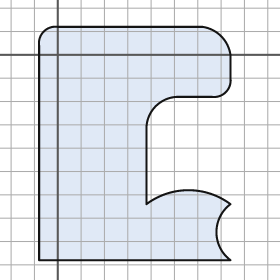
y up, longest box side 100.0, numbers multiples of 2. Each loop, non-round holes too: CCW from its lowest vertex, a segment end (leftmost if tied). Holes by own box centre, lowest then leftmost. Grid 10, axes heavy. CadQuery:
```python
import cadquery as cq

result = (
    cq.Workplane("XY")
    .moveTo(-8.0, -88.0)
    .lineTo(74.0, -88.0)
    .threePointArc((68.0, -76.0), (74.0, -64.0))
    .threePointArc((56.0, -58.0), (38.0, -64.0))
    .lineTo(38.0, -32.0)
    .threePointArc((42.0, -22.0), (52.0, -18.0))
    .lineTo(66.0, -18.0)
    .threePointArc((72.0, -16.0), (74.0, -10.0))
    .lineTo(74.0, 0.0)
    .threePointArc((70.0, 8.0), (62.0, 12.0))
    .lineTo(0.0, 12.0)
    .threePointArc((-6.0, 10.0), (-8.0, 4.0))
    .close()
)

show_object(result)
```